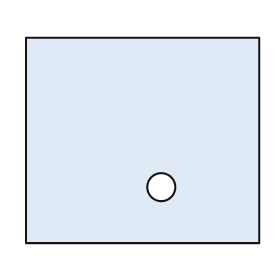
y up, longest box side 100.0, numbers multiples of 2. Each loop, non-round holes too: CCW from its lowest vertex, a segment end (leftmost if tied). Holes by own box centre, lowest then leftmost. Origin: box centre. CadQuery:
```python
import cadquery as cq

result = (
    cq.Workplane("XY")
    .moveTo(-50.0, -44.0)
    .lineTo(50.0, -44.0)
    .lineTo(50.0, 44.0)
    .lineTo(-50.0, 44.0)
    .close()
    .moveTo(8.0, -20.0)
    .circle(6.0)
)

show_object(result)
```